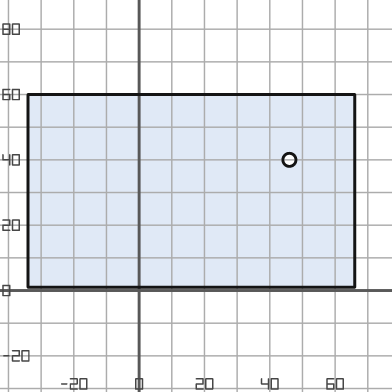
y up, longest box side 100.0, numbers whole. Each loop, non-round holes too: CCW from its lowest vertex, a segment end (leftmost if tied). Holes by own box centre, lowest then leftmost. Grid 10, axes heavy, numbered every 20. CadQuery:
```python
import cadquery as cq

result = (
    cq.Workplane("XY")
    .moveTo(-34.0, 1.0)
    .lineTo(66.0, 1.0)
    .lineTo(66.0, 60.0)
    .lineTo(-34.0, 60.0)
    .close()
    .moveTo(46.0, 40.0)
    .circle(2.0)
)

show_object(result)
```